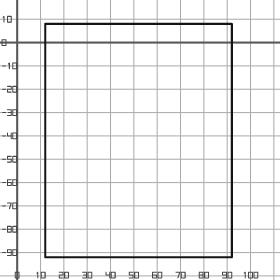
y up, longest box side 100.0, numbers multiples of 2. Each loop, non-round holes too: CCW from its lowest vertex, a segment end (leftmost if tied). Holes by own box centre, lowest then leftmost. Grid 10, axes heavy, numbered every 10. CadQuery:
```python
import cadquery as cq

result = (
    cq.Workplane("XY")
    .moveTo(12.0, -92.0)
    .lineTo(92.0, -92.0)
    .lineTo(92.0, 8.0)
    .lineTo(12.0, 8.0)
    .close()
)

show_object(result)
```